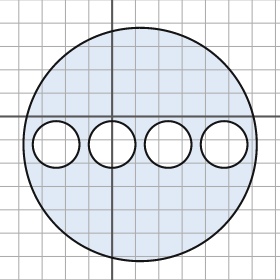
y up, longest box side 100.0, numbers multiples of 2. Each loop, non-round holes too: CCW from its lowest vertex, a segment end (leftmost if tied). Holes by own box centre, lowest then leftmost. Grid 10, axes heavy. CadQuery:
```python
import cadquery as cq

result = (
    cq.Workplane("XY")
    .moveTo(12.0, -12.0)
    .circle(50.0)
    .moveTo(-24.0, -12.0)
    .circle(10.0)
    .moveTo(0.0, -12.0)
    .circle(10.0)
    .moveTo(24.0, -12.0)
    .circle(10.0)
    .moveTo(48.0, -12.0)
    .circle(10.0)
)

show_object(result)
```